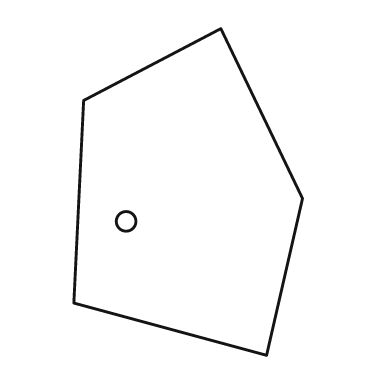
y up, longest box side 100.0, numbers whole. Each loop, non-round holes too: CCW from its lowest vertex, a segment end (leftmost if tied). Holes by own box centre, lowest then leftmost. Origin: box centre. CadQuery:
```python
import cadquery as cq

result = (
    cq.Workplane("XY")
    .moveTo(24.0, -50.0)
    .lineTo(35.0, -2.0)
    .lineTo(10.0, 50.0)
    .lineTo(-32.0, 28.0)
    .lineTo(-35.0, -34.0)
    .close()
    .moveTo(-19.0, -9.0)
    .circle(3.0)
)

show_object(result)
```